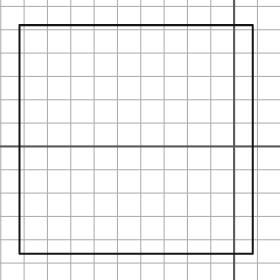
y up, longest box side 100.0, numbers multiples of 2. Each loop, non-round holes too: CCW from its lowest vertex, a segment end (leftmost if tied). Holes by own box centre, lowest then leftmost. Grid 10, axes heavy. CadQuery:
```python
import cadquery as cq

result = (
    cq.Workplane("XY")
    .moveTo(-92.0, -46.0)
    .lineTo(8.0, -46.0)
    .lineTo(8.0, 52.0)
    .lineTo(-92.0, 52.0)
    .close()
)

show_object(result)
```